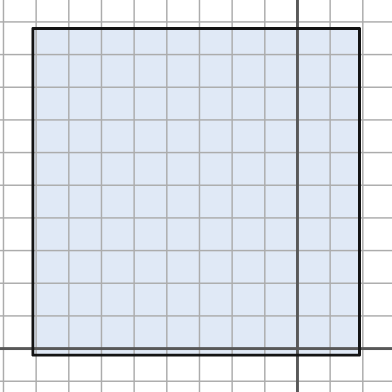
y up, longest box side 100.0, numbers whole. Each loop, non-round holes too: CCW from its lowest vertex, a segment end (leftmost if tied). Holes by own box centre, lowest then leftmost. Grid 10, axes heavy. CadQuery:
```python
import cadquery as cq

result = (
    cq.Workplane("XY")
    .moveTo(-81.0, -2.0)
    .lineTo(19.0, -2.0)
    .lineTo(19.0, 98.0)
    .lineTo(-81.0, 98.0)
    .close()
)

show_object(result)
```